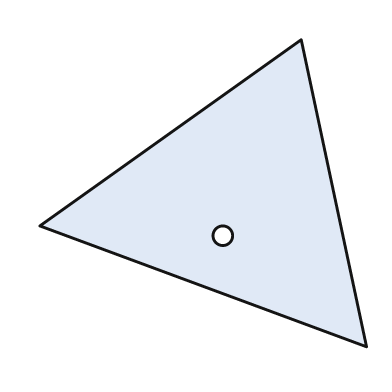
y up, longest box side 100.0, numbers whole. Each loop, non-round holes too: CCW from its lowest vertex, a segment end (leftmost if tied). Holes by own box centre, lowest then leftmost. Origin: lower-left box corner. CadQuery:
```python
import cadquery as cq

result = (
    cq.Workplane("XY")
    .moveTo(100.0, 0.0)
    .lineTo(80.0, 94.0)
    .lineTo(0.0, 37.0)
    .close()
    .moveTo(56.0, 34.0)
    .circle(3.0)
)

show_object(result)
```